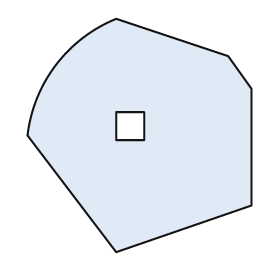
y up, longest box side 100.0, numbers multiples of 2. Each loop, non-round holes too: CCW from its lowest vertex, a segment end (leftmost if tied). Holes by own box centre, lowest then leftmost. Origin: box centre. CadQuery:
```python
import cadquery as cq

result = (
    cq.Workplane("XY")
    .moveTo(-10.0, -50.0)
    .lineTo(48.0, -30.0)
    .lineTo(48.0, 20.0)
    .lineTo(38.0, 34.0)
    .lineTo(-10.0, 50.0)
    .threePointArc((-36.0, 30.0), (-48.0, 0.0))
    .close()
    .moveTo(-10.0, -2.0)
    .lineTo(2.0, -2.0)
    .lineTo(2.0, 10.0)
    .lineTo(-10.0, 10.0)
    .close()
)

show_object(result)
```